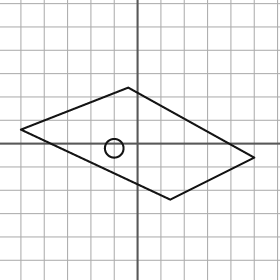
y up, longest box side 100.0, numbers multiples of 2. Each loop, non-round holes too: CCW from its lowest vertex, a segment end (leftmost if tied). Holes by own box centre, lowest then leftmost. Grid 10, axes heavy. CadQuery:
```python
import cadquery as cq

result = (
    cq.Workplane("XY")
    .moveTo(14.0, -24.0)
    .lineTo(50.0, -6.0)
    .lineTo(-4.0, 24.0)
    .lineTo(-50.0, 6.0)
    .close()
    .moveTo(-10.0, -2.0)
    .circle(4.0)
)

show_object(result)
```